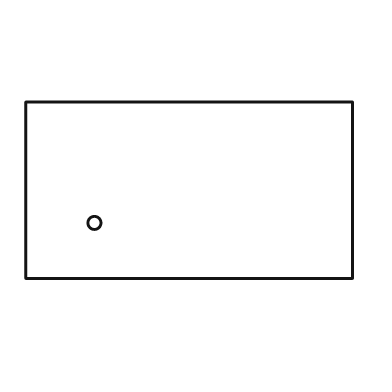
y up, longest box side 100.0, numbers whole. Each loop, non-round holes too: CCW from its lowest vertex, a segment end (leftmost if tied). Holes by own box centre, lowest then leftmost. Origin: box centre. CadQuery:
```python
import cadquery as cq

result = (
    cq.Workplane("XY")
    .moveTo(-50.0, -27.0)
    .lineTo(50.0, -27.0)
    .lineTo(50.0, 27.0)
    .lineTo(-50.0, 27.0)
    .close()
    .moveTo(-29.0, -10.0)
    .circle(2.0)
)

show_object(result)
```